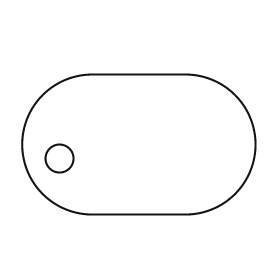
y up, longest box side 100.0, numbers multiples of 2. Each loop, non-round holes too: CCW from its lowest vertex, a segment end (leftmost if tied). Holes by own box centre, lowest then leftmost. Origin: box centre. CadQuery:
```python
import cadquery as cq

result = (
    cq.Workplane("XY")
    .moveTo(-20.0, -30.0)
    .lineTo(20.0, -30.0)
    .threePointArc((50.0, 0.0), (20.0, 30.0))
    .lineTo(-20.0, 30.0)
    .threePointArc((-50.0, 0.0), (-20.0, -30.0))
    .close()
    .moveTo(-34.0, -6.0)
    .circle(6.0)
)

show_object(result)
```